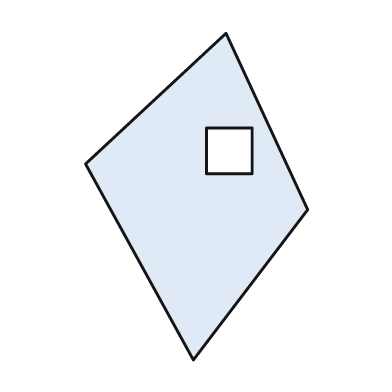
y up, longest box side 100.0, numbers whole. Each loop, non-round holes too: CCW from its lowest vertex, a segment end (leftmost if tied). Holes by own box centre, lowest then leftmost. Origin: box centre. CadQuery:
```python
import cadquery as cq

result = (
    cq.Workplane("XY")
    .moveTo(-1.0, -50.0)
    .lineTo(34.0, -4.0)
    .lineTo(9.0, 50.0)
    .lineTo(-34.0, 10.0)
    .close()
    .moveTo(3.0, 7.0)
    .lineTo(17.0, 7.0)
    .lineTo(17.0, 21.0)
    .lineTo(3.0, 21.0)
    .close()
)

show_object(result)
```